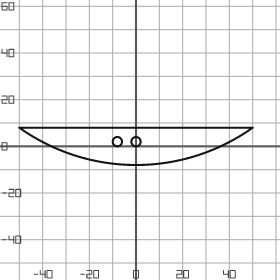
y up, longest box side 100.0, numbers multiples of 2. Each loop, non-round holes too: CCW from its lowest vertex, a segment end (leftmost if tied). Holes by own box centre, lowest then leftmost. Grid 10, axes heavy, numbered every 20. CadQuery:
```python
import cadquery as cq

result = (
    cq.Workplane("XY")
    .moveTo(-50.0, 8.0)
    .threePointArc((0.0, -8.0), (50.0, 8.0))
    .close()
    .moveTo(-8.0, 2.0)
    .circle(2.0)
    .moveTo(0.0, 2.0)
    .circle(2.0)
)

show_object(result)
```